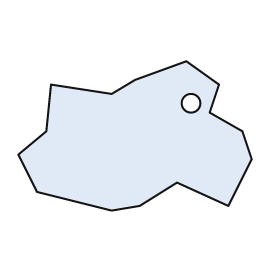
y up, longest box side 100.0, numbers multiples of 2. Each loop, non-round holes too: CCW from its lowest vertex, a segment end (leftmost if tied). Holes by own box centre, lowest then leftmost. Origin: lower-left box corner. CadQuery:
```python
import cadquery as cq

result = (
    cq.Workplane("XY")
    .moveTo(40.0, 0.0)
    .lineTo(52.0, 2.0)
    .lineTo(68.0, 12.0)
    .lineTo(90.0, 2.0)
    .lineTo(100.0, 22.0)
    .lineTo(96.0, 34.0)
    .lineTo(82.0, 42.0)
    .lineTo(86.0, 54.0)
    .lineTo(72.0, 64.0)
    .lineTo(50.0, 56.0)
    .lineTo(40.0, 50.0)
    .lineTo(14.0, 54.0)
    .lineTo(12.0, 34.0)
    .lineTo(0.0, 24.0)
    .lineTo(8.0, 8.0)
    .close()
    .moveTo(74.0, 46.0)
    .circle(4.0)
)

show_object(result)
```